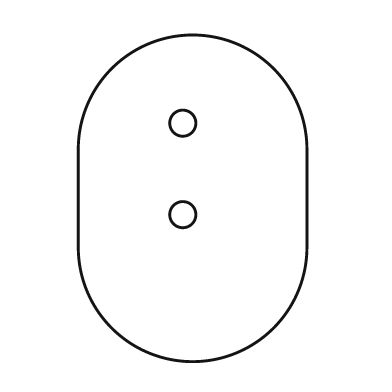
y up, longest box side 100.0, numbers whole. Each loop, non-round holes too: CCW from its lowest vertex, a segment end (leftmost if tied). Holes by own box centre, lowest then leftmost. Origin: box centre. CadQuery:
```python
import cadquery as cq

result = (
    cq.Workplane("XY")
    .moveTo(-35.0, -15.0)
    .threePointArc((0.0, -50.0), (35.0, -15.0))
    .lineTo(35.0, 15.0)
    .threePointArc((0.0, 50.0), (-35.0, 15.0))
    .close()
    .moveTo(-3.0, -5.0)
    .circle(4.0)
    .moveTo(-3.0, 23.0)
    .circle(4.0)
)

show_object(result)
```